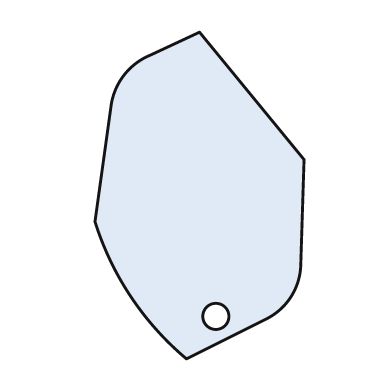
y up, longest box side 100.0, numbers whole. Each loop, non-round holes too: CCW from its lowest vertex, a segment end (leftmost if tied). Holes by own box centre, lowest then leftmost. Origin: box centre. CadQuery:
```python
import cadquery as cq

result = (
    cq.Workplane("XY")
    .moveTo(-4.0, -50.0)
    .lineTo(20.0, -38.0)
    .threePointArc((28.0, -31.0), (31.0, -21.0))
    .lineTo(32.0, 11.0)
    .lineTo(0.0, 50.0)
    .lineTo(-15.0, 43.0)
    .threePointArc((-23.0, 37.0), (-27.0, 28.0))
    .lineTo(-32.0, -8.0)
    .threePointArc((-21.0, -31.0), (-4.0, -50.0))
    .close()
    .moveTo(5.0, -37.0)
    .circle(4.0)
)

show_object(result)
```